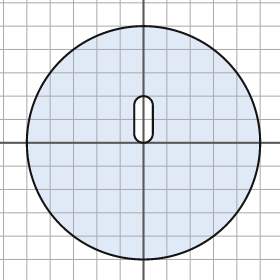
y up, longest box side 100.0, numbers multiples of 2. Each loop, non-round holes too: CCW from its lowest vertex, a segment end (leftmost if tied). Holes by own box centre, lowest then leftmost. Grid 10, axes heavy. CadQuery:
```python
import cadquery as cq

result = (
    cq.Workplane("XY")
    .moveTo(0.0, 0.0)
    .circle(50.0)
    .moveTo(-4.0, 4.0)
    .threePointArc((0.0, 0.0), (4.0, 4.0))
    .lineTo(4.0, 16.0)
    .threePointArc((0.0, 20.0), (-4.0, 16.0))
    .close()
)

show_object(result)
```